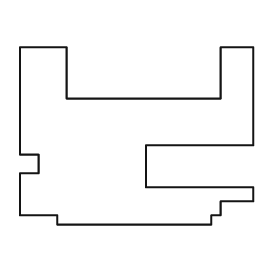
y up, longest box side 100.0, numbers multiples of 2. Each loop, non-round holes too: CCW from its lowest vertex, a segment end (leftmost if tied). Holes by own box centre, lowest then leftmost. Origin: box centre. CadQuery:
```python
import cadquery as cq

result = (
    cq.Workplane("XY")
    .moveTo(-34.0, -38.0)
    .lineTo(32.0, -38.0)
    .lineTo(32.0, -34.0)
    .lineTo(36.0, -34.0)
    .lineTo(36.0, -28.0)
    .lineTo(50.0, -28.0)
    .lineTo(50.0, -22.0)
    .lineTo(4.0, -22.0)
    .lineTo(4.0, -4.0)
    .lineTo(50.0, -4.0)
    .lineTo(50.0, 38.0)
    .lineTo(36.0, 38.0)
    .lineTo(36.0, 16.0)
    .lineTo(-30.0, 16.0)
    .lineTo(-30.0, 38.0)
    .lineTo(-50.0, 38.0)
    .lineTo(-50.0, -8.0)
    .lineTo(-42.0, -8.0)
    .lineTo(-42.0, -16.0)
    .lineTo(-50.0, -16.0)
    .lineTo(-50.0, -34.0)
    .lineTo(-34.0, -34.0)
    .close()
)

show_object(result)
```